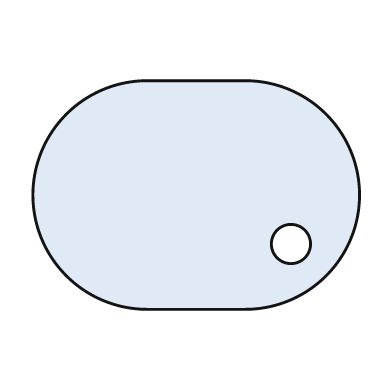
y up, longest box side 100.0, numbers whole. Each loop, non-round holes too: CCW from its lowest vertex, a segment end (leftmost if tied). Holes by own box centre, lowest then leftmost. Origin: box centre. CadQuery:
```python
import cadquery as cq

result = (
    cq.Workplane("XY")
    .moveTo(-15.0, -35.0)
    .lineTo(15.0, -35.0)
    .threePointArc((50.0, 0.0), (15.0, 35.0))
    .lineTo(-15.0, 35.0)
    .threePointArc((-50.0, 0.0), (-15.0, -35.0))
    .close()
    .moveTo(29.0, -15.0)
    .circle(6.0)
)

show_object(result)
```